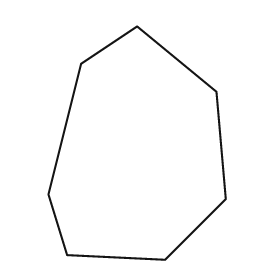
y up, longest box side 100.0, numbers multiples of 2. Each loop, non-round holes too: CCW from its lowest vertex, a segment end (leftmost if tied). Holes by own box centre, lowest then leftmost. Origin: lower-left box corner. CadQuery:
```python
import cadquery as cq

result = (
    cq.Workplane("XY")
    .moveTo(50.0, 0.0)
    .lineTo(76.0, 26.0)
    .lineTo(72.0, 72.0)
    .lineTo(38.0, 100.0)
    .lineTo(14.0, 84.0)
    .lineTo(0.0, 28.0)
    .lineTo(8.0, 2.0)
    .close()
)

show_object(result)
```